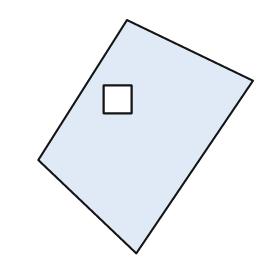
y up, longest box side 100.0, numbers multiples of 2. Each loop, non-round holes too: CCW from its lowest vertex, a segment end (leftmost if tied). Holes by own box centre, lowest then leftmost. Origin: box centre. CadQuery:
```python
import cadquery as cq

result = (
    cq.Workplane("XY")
    .moveTo(-4.0, -50.0)
    .lineTo(46.0, 24.0)
    .lineTo(-8.0, 50.0)
    .lineTo(-46.0, -10.0)
    .close()
    .moveTo(-18.0, 10.0)
    .lineTo(-6.0, 10.0)
    .lineTo(-6.0, 22.0)
    .lineTo(-18.0, 22.0)
    .close()
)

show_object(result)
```